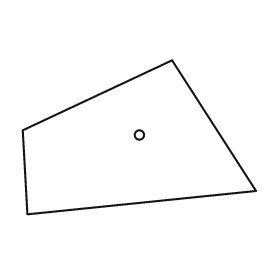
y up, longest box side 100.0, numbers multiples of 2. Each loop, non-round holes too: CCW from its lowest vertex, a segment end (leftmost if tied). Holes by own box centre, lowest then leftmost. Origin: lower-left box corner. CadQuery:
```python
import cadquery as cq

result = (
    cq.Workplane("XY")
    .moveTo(2.0, 0.0)
    .lineTo(100.0, 10.0)
    .lineTo(64.0, 66.0)
    .lineTo(0.0, 36.0)
    .close()
    .moveTo(50.0, 34.0)
    .circle(2.0)
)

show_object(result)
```